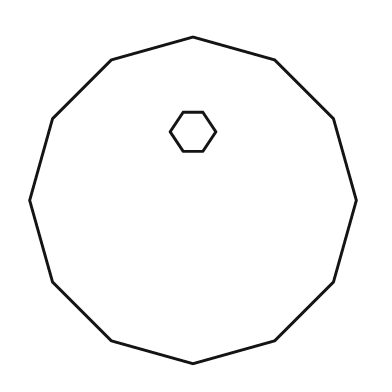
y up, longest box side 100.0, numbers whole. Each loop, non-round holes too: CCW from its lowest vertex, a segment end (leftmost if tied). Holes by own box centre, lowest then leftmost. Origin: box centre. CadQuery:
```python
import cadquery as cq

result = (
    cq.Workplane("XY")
    .moveTo(0.0, -50.0)
    .lineTo(25.0, -43.0)
    .lineTo(43.0, -25.0)
    .lineTo(50.0, 0.0)
    .lineTo(43.0, 25.0)
    .lineTo(25.0, 43.0)
    .lineTo(0.0, 50.0)
    .lineTo(-25.0, 43.0)
    .lineTo(-43.0, 25.0)
    .lineTo(-50.0, 0.0)
    .lineTo(-43.0, -25.0)
    .lineTo(-25.0, -43.0)
    .close()
    .moveTo(-3.0, 15.0)
    .lineTo(3.0, 15.0)
    .lineTo(7.0, 21.0)
    .lineTo(3.0, 27.0)
    .lineTo(-3.0, 27.0)
    .lineTo(-7.0, 21.0)
    .close()
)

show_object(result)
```